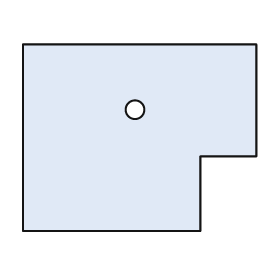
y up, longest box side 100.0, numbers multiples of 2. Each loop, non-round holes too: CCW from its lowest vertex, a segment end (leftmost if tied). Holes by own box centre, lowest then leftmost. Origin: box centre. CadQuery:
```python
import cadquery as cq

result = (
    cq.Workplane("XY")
    .moveTo(-50.0, -40.0)
    .lineTo(26.0, -40.0)
    .lineTo(26.0, -8.0)
    .lineTo(50.0, -8.0)
    .lineTo(50.0, 40.0)
    .lineTo(-50.0, 40.0)
    .close()
    .moveTo(-2.0, 12.0)
    .circle(4.0)
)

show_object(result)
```